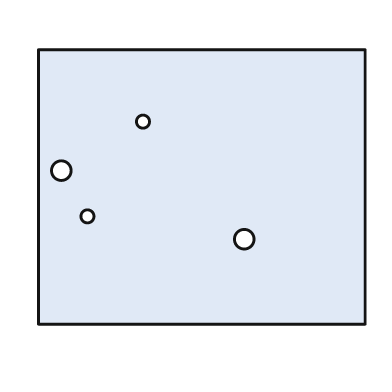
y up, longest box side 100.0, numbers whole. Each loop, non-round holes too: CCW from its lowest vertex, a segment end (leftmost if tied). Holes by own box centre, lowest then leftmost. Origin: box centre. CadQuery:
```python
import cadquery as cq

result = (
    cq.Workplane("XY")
    .moveTo(-50.0, -42.0)
    .lineTo(50.0, -42.0)
    .lineTo(50.0, 42.0)
    .lineTo(-50.0, 42.0)
    .close()
    .moveTo(13.0, -16.0)
    .circle(3.0)
    .moveTo(-35.0, -9.0)
    .circle(2.0)
    .moveTo(-43.0, 5.0)
    .circle(3.0)
    .moveTo(-18.0, 20.0)
    .circle(2.0)
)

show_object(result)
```